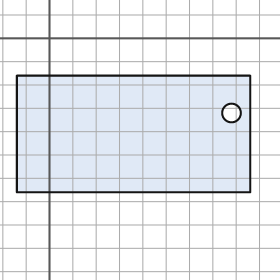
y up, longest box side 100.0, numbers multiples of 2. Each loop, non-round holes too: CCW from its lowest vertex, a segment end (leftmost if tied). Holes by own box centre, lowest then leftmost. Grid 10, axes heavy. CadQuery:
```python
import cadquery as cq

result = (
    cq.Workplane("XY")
    .moveTo(-14.0, -66.0)
    .lineTo(86.0, -66.0)
    .lineTo(86.0, -16.0)
    .lineTo(-14.0, -16.0)
    .close()
    .moveTo(78.0, -32.0)
    .circle(4.0)
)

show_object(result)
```